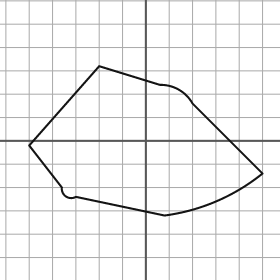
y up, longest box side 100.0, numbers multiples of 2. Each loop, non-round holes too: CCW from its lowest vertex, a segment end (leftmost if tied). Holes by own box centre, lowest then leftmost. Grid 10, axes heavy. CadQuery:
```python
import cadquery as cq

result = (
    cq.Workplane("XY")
    .moveTo(8.0, -32.0)
    .threePointArc((30.0, -26.0), (50.0, -14.0))
    .lineTo(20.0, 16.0)
    .threePointArc((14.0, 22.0), (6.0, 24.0))
    .lineTo(-20.0, 32.0)
    .lineTo(-50.0, -2.0)
    .lineTo(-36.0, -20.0)
    .threePointArc((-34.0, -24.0), (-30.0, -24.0))
    .close()
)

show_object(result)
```